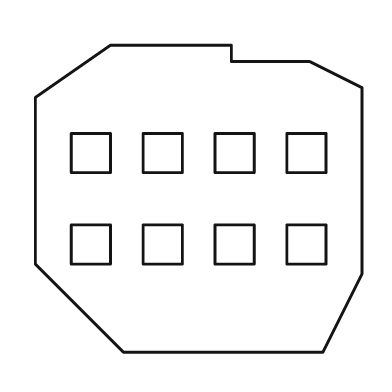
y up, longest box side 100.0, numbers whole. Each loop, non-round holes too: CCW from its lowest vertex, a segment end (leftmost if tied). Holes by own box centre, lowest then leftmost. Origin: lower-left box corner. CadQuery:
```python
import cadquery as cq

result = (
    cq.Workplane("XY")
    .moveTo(27.0, 0.0)
    .lineTo(88.0, 0.0)
    .lineTo(100.0, 24.0)
    .lineTo(100.0, 81.0)
    .lineTo(84.0, 89.0)
    .lineTo(60.0, 89.0)
    .lineTo(60.0, 94.0)
    .lineTo(23.0, 94.0)
    .lineTo(0.0, 78.0)
    .lineTo(0.0, 27.0)
    .close()
    .moveTo(11.0, 27.0)
    .lineTo(23.0, 27.0)
    .lineTo(23.0, 39.0)
    .lineTo(11.0, 39.0)
    .close()
    .moveTo(33.0, 27.0)
    .lineTo(45.0, 27.0)
    .lineTo(45.0, 39.0)
    .lineTo(33.0, 39.0)
    .close()
    .moveTo(55.0, 27.0)
    .lineTo(67.0, 27.0)
    .lineTo(67.0, 39.0)
    .lineTo(55.0, 39.0)
    .close()
    .moveTo(77.0, 27.0)
    .lineTo(89.0, 27.0)
    .lineTo(89.0, 39.0)
    .lineTo(77.0, 39.0)
    .close()
    .moveTo(11.0, 55.0)
    .lineTo(23.0, 55.0)
    .lineTo(23.0, 67.0)
    .lineTo(11.0, 67.0)
    .close()
    .moveTo(33.0, 55.0)
    .lineTo(45.0, 55.0)
    .lineTo(45.0, 67.0)
    .lineTo(33.0, 67.0)
    .close()
    .moveTo(55.0, 55.0)
    .lineTo(67.0, 55.0)
    .lineTo(67.0, 67.0)
    .lineTo(55.0, 67.0)
    .close()
    .moveTo(77.0, 55.0)
    .lineTo(89.0, 55.0)
    .lineTo(89.0, 67.0)
    .lineTo(77.0, 67.0)
    .close()
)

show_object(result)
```